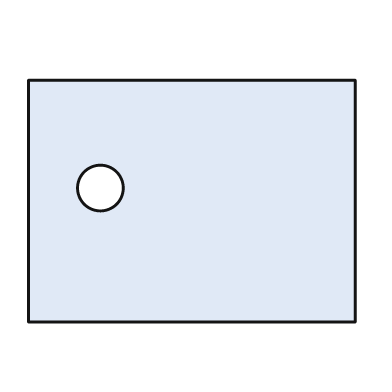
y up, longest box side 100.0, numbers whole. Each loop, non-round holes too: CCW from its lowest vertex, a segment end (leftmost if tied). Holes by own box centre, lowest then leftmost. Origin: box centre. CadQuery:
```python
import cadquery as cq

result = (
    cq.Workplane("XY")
    .moveTo(-50.0, -37.0)
    .lineTo(50.0, -37.0)
    .lineTo(50.0, 37.0)
    .lineTo(-50.0, 37.0)
    .close()
    .moveTo(-28.0, 4.0)
    .circle(7.0)
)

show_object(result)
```